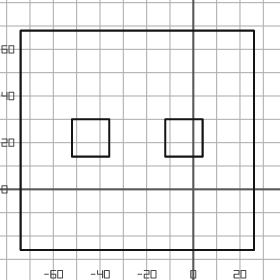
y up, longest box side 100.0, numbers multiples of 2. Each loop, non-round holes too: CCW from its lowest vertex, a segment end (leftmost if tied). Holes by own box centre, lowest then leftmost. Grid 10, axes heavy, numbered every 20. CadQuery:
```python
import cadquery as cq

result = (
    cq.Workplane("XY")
    .moveTo(-74.0, -26.0)
    .lineTo(26.0, -26.0)
    .lineTo(26.0, 68.0)
    .lineTo(-74.0, 68.0)
    .close()
    .moveTo(-52.0, 14.0)
    .lineTo(-36.0, 14.0)
    .lineTo(-36.0, 30.0)
    .lineTo(-52.0, 30.0)
    .close()
    .moveTo(-12.0, 14.0)
    .lineTo(4.0, 14.0)
    .lineTo(4.0, 30.0)
    .lineTo(-12.0, 30.0)
    .close()
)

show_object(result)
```